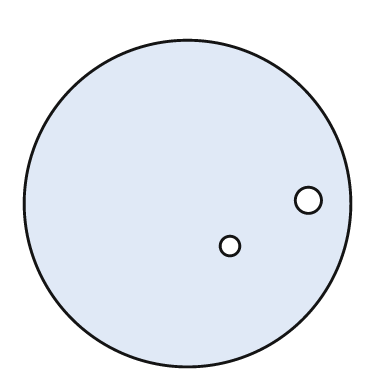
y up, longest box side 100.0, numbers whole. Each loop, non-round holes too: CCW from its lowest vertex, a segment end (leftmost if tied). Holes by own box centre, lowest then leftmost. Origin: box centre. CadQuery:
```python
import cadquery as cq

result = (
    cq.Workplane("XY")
    .moveTo(0.0, 0.0)
    .circle(50.0)
    .moveTo(13.0, -13.0)
    .circle(3.0)
    .moveTo(37.0, 1.0)
    .circle(4.0)
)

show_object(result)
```